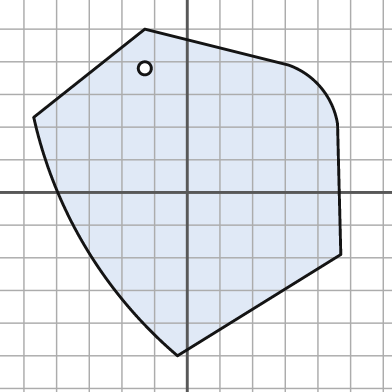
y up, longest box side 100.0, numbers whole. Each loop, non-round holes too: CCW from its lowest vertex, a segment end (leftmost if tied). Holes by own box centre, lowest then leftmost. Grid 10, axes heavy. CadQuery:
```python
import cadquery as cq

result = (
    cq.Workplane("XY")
    .moveTo(-3.0, -50.0)
    .lineTo(47.0, -19.0)
    .lineTo(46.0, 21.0)
    .threePointArc((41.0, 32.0), (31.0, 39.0))
    .lineTo(-13.0, 50.0)
    .lineTo(-47.0, 23.0)
    .threePointArc((-31.0, -17.0), (-3.0, -50.0))
    .close()
    .moveTo(-13.0, 38.0)
    .circle(2.0)
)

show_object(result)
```